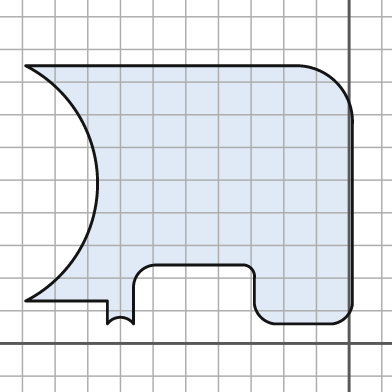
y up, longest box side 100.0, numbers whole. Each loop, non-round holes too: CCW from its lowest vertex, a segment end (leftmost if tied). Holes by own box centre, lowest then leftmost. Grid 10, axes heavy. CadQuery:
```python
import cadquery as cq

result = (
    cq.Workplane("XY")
    .moveTo(-74.0, 6.0)
    .threePointArc((-70.0, 8.0), (-66.0, 6.0))
    .lineTo(-66.0, 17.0)
    .threePointArc((-64.0, 22.0), (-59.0, 24.0))
    .lineTo(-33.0, 24.0)
    .threePointArc((-30.0, 23.0), (-29.0, 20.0))
    .lineTo(-29.0, 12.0)
    .threePointArc((-27.0, 8.0), (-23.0, 6.0))
    .lineTo(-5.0, 6.0)
    .threePointArc((-1.0, 8.0), (1.0, 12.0))
    .lineTo(1.0, 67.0)
    .threePointArc((-4.0, 80.0), (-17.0, 85.0))
    .lineTo(-99.0, 85.0)
    .threePointArc((-77.0, 49.0), (-99.0, 13.0))
    .lineTo(-74.0, 13.0)
    .close()
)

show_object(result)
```